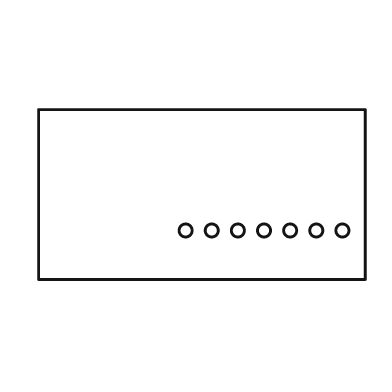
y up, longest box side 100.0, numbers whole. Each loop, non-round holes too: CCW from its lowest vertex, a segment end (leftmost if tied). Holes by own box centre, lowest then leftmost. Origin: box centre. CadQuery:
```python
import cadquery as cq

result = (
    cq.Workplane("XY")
    .moveTo(-50.0, -26.0)
    .lineTo(50.0, -26.0)
    .lineTo(50.0, 26.0)
    .lineTo(-50.0, 26.0)
    .close()
    .moveTo(-5.0, -11.0)
    .circle(2.0)
    .moveTo(3.0, -11.0)
    .circle(2.0)
    .moveTo(11.0, -11.0)
    .circle(2.0)
    .moveTo(19.0, -11.0)
    .circle(2.0)
    .moveTo(27.0, -11.0)
    .circle(2.0)
    .moveTo(35.0, -11.0)
    .circle(2.0)
    .moveTo(43.0, -11.0)
    .circle(2.0)
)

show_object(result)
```